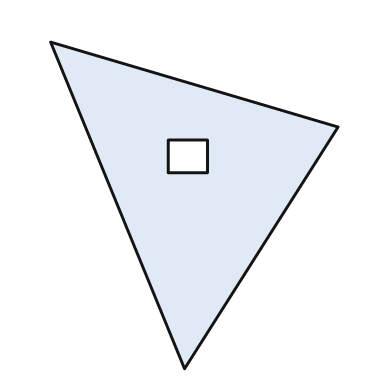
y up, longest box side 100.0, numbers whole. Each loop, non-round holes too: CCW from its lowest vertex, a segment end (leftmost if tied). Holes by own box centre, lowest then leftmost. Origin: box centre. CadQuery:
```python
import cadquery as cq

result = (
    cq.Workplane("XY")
    .moveTo(-3.0, -50.0)
    .lineTo(44.0, 24.0)
    .lineTo(-44.0, 50.0)
    .close()
    .moveTo(-8.0, 10.0)
    .lineTo(4.0, 10.0)
    .lineTo(4.0, 20.0)
    .lineTo(-8.0, 20.0)
    .close()
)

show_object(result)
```